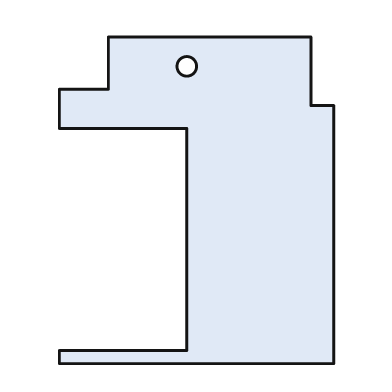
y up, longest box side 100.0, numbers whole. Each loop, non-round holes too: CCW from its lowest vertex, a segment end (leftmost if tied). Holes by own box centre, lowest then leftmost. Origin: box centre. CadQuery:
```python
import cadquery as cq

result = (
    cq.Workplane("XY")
    .moveTo(-42.0, -50.0)
    .lineTo(42.0, -50.0)
    .lineTo(42.0, 29.0)
    .lineTo(35.0, 29.0)
    .lineTo(35.0, 50.0)
    .lineTo(-27.0, 50.0)
    .lineTo(-27.0, 34.0)
    .lineTo(-42.0, 34.0)
    .lineTo(-42.0, 22.0)
    .lineTo(-3.0, 22.0)
    .lineTo(-3.0, -46.0)
    .lineTo(-42.0, -46.0)
    .close()
    .moveTo(-3.0, 41.0)
    .circle(3.0)
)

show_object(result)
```